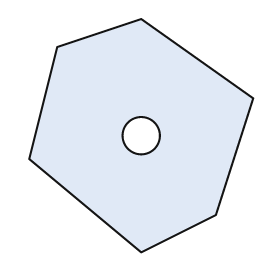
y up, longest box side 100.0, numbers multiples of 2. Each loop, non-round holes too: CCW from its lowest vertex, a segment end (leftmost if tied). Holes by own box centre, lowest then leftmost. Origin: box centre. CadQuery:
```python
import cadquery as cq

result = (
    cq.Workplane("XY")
    .moveTo(0.0, -50.0)
    .lineTo(32.0, -34.0)
    .lineTo(48.0, 16.0)
    .lineTo(0.0, 50.0)
    .lineTo(-36.0, 38.0)
    .lineTo(-48.0, -10.0)
    .close()
    .moveTo(0.0, 0.0)
    .circle(8.0)
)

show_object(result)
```